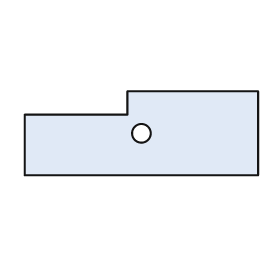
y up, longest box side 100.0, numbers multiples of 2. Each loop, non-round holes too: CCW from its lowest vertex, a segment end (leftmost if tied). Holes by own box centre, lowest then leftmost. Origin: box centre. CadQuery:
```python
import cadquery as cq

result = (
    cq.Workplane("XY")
    .moveTo(-50.0, -18.0)
    .lineTo(50.0, -18.0)
    .lineTo(50.0, 18.0)
    .lineTo(-6.0, 18.0)
    .lineTo(-6.0, 8.0)
    .lineTo(-50.0, 8.0)
    .close()
    .moveTo(0.0, 0.0)
    .circle(4.0)
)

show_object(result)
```